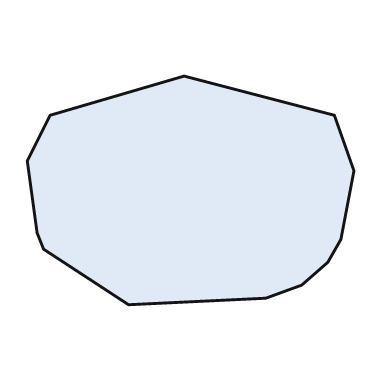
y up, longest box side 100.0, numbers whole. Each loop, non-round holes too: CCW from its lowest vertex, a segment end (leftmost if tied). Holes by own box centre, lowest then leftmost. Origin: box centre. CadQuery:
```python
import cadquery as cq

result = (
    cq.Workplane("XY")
    .moveTo(-19.0, -35.0)
    .lineTo(23.0, -33.0)
    .lineTo(34.0, -29.0)
    .lineTo(42.0, -22.0)
    .lineTo(46.0, -15.0)
    .lineTo(50.0, 6.0)
    .lineTo(44.0, 23.0)
    .lineTo(-2.0, 35.0)
    .lineTo(-43.0, 23.0)
    .lineTo(-50.0, 9.0)
    .lineTo(-47.0, -13.0)
    .lineTo(-45.0, -18.0)
    .close()
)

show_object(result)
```